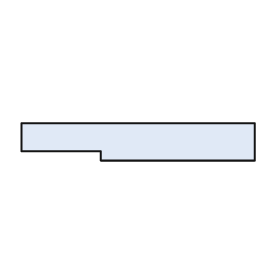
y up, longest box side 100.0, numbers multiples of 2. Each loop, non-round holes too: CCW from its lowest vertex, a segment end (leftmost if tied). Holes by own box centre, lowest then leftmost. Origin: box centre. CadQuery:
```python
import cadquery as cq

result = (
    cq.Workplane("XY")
    .moveTo(-16.0, -8.0)
    .lineTo(50.0, -8.0)
    .lineTo(50.0, 8.0)
    .lineTo(-50.0, 8.0)
    .lineTo(-50.0, -4.0)
    .lineTo(-16.0, -4.0)
    .close()
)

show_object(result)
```